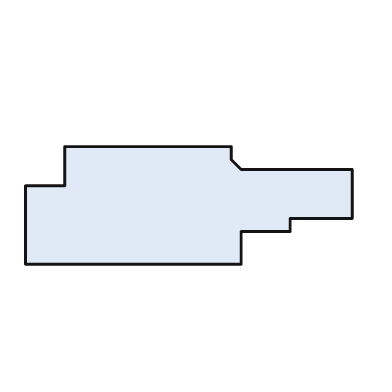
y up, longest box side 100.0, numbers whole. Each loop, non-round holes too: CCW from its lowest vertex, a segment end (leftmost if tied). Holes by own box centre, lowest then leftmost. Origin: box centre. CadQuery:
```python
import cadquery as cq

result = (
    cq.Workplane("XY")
    .moveTo(-50.0, -18.0)
    .lineTo(16.0, -18.0)
    .lineTo(16.0, -8.0)
    .lineTo(31.0, -8.0)
    .lineTo(31.0, -4.0)
    .lineTo(50.0, -4.0)
    .lineTo(50.0, 11.0)
    .lineTo(16.0, 11.0)
    .lineTo(13.0, 14.0)
    .lineTo(13.0, 18.0)
    .lineTo(-38.0, 18.0)
    .lineTo(-38.0, 6.0)
    .lineTo(-50.0, 6.0)
    .close()
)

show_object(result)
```